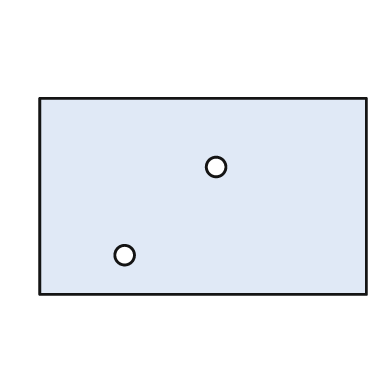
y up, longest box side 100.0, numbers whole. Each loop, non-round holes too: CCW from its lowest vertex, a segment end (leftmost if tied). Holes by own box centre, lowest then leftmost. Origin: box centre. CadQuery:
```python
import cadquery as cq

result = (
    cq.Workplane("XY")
    .moveTo(-50.0, -30.0)
    .lineTo(50.0, -30.0)
    .lineTo(50.0, 30.0)
    .lineTo(-50.0, 30.0)
    .close()
    .moveTo(-24.0, -18.0)
    .circle(3.0)
    .moveTo(4.0, 9.0)
    .circle(3.0)
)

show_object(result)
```